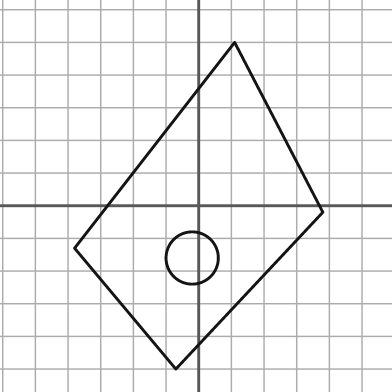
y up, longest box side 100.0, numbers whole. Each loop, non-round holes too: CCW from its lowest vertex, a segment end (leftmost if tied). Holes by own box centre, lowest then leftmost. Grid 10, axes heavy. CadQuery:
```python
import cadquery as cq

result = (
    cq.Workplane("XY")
    .moveTo(-7.0, -50.0)
    .lineTo(38.0, -2.0)
    .lineTo(11.0, 50.0)
    .lineTo(-38.0, -13.0)
    .close()
    .moveTo(-2.0, -16.0)
    .circle(8.0)
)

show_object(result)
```